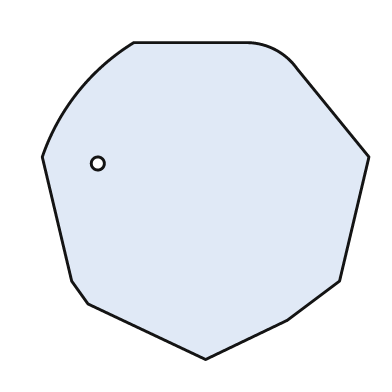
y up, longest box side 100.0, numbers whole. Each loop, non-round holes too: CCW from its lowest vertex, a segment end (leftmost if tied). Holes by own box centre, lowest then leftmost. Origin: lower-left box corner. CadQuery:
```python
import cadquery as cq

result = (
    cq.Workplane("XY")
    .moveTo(50.0, 0.0)
    .lineTo(75.0, 12.0)
    .lineTo(91.0, 24.0)
    .lineTo(100.0, 62.0)
    .lineTo(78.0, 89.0)
    .threePointArc((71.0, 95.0), (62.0, 97.0))
    .lineTo(28.0, 97.0)
    .threePointArc((11.0, 82.0), (0.0, 62.0))
    .lineTo(9.0, 24.0)
    .lineTo(14.0, 17.0)
    .close()
    .moveTo(17.0, 60.0)
    .circle(2.0)
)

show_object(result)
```